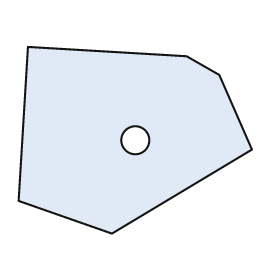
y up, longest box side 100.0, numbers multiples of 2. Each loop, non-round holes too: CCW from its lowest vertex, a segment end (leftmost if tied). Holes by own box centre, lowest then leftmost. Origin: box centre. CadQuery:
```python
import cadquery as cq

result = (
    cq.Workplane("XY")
    .moveTo(-10.0, -40.0)
    .lineTo(50.0, -4.0)
    .lineTo(36.0, 28.0)
    .lineTo(22.0, 36.0)
    .lineTo(-46.0, 40.0)
    .lineTo(-50.0, -26.0)
    .close()
    .moveTo(0.0, 0.0)
    .circle(6.0)
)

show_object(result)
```